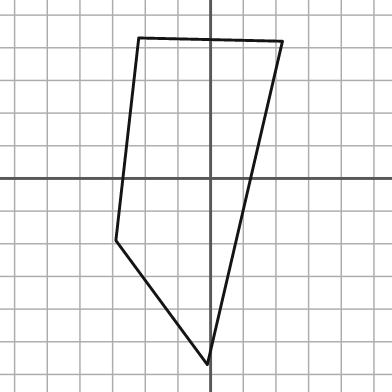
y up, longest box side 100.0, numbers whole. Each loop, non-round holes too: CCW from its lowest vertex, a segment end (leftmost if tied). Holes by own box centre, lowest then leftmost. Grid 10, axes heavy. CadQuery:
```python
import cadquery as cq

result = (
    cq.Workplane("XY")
    .moveTo(-1.0, -57.0)
    .lineTo(22.0, 42.0)
    .lineTo(-22.0, 43.0)
    .lineTo(-29.0, -19.0)
    .close()
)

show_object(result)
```